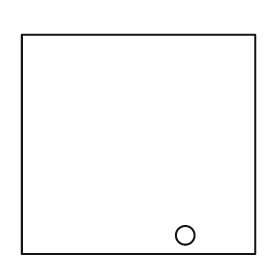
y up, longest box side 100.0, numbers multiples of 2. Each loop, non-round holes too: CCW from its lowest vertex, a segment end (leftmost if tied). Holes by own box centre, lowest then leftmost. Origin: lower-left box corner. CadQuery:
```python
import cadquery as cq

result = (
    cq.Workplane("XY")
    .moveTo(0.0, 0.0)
    .lineTo(100.0, 0.0)
    .lineTo(100.0, 94.0)
    .lineTo(0.0, 94.0)
    .close()
    .moveTo(70.0, 8.0)
    .circle(4.0)
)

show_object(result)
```